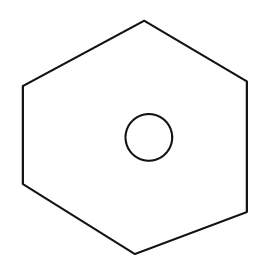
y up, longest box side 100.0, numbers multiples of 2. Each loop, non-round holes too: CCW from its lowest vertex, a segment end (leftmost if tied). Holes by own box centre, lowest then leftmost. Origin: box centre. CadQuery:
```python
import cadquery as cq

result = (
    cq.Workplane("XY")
    .moveTo(0.0, -50.0)
    .lineTo(48.0, -32.0)
    .lineTo(48.0, 24.0)
    .lineTo(4.0, 50.0)
    .lineTo(-48.0, 22.0)
    .lineTo(-48.0, -20.0)
    .close()
    .moveTo(6.0, 0.0)
    .circle(10.0)
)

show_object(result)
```